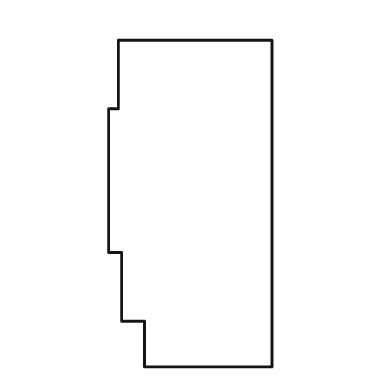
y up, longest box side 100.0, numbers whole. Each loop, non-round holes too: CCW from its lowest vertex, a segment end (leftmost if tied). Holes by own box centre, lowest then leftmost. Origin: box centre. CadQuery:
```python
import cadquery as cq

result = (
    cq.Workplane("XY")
    .moveTo(-14.0, -50.0)
    .lineTo(25.0, -50.0)
    .lineTo(25.0, 50.0)
    .lineTo(-22.0, 50.0)
    .lineTo(-22.0, 29.0)
    .lineTo(-25.0, 29.0)
    .lineTo(-25.0, -15.0)
    .lineTo(-21.0, -15.0)
    .lineTo(-21.0, -36.0)
    .lineTo(-14.0, -36.0)
    .close()
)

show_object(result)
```